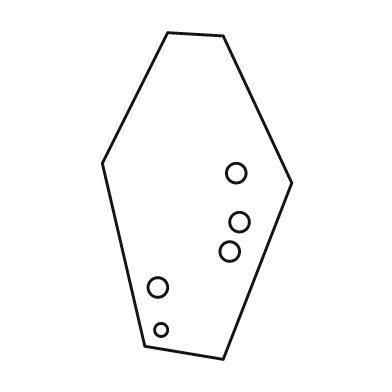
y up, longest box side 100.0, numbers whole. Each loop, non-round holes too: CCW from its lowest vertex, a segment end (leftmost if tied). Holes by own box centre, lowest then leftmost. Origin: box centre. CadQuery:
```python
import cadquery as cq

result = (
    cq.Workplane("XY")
    .moveTo(8.0, -50.0)
    .lineTo(29.0, 4.0)
    .lineTo(8.0, 49.0)
    .lineTo(-9.0, 50.0)
    .lineTo(-29.0, 10.0)
    .lineTo(-16.0, -46.0)
    .close()
    .moveTo(-11.0, -41.0)
    .circle(2.0)
    .moveTo(-12.0, -28.0)
    .circle(3.0)
    .moveTo(10.0, -17.0)
    .circle(3.0)
    .moveTo(13.0, -8.0)
    .circle(3.0)
    .moveTo(12.0, 7.0)
    .circle(3.0)
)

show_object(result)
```